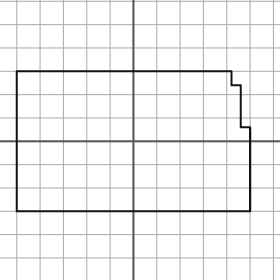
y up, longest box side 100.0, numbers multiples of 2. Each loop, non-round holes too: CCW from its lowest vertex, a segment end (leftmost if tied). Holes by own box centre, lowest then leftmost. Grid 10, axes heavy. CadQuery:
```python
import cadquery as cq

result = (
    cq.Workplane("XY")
    .moveTo(-50.0, -30.0)
    .lineTo(50.0, -30.0)
    .lineTo(50.0, 6.0)
    .lineTo(46.0, 6.0)
    .lineTo(46.0, 24.0)
    .lineTo(42.0, 24.0)
    .lineTo(42.0, 30.0)
    .lineTo(-50.0, 30.0)
    .close()
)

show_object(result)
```